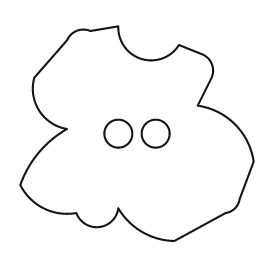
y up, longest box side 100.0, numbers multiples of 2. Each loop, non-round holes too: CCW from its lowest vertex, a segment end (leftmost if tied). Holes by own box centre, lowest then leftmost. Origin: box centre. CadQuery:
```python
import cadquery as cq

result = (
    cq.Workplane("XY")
    .moveTo(16.0, -46.0)
    .lineTo(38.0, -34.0)
    .threePointArc((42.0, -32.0), (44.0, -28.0))
    .lineTo(50.0, -12.0)
    .threePointArc((42.0, 4.0), (26.0, 12.0))
    .lineTo(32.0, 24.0)
    .threePointArc((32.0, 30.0), (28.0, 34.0))
    .lineTo(18.0, 38.0)
    .threePointArc((2.0, 32.0), (-8.0, 46.0))
    .lineTo(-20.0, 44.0)
    .threePointArc((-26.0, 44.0), (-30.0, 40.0))
    .lineTo(-44.0, 24.0)
    .threePointArc((-42.0, 10.0), (-30.0, 2.0))
    .threePointArc((-42.0, -8.0), (-50.0, -22.0))
    .threePointArc((-40.0, -32.0), (-26.0, -34.0))
    .threePointArc((-16.0, -40.0), (-8.0, -32.0))
    .threePointArc((2.0, -42.0), (16.0, -46.0))
    .close()
    .moveTo(-8.0, 0.0)
    .circle(6.0)
    .moveTo(8.0, 0.0)
    .circle(6.0)
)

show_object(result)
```